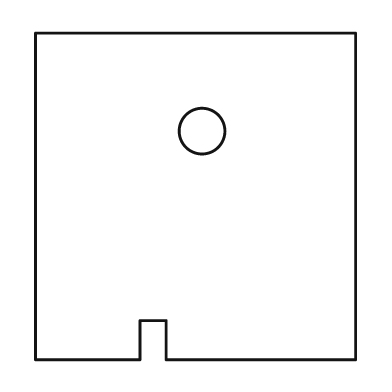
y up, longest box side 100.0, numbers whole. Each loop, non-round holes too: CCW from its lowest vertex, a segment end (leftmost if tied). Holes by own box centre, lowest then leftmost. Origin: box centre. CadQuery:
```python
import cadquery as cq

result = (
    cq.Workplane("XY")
    .moveTo(-49.0, -50.0)
    .lineTo(-17.0, -50.0)
    .lineTo(-17.0, -38.0)
    .lineTo(-9.0, -38.0)
    .lineTo(-9.0, -50.0)
    .lineTo(49.0, -50.0)
    .lineTo(49.0, 50.0)
    .lineTo(-49.0, 50.0)
    .close()
    .moveTo(2.0, 20.0)
    .circle(7.0)
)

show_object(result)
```